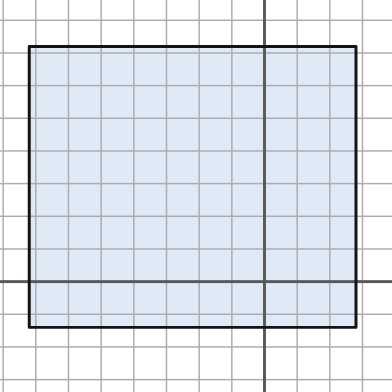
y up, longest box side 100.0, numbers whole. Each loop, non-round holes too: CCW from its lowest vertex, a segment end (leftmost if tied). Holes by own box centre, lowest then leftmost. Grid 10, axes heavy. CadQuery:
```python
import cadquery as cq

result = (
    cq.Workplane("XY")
    .moveTo(-72.0, -14.0)
    .lineTo(28.0, -14.0)
    .lineTo(28.0, 72.0)
    .lineTo(-72.0, 72.0)
    .close()
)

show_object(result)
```